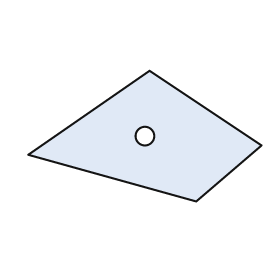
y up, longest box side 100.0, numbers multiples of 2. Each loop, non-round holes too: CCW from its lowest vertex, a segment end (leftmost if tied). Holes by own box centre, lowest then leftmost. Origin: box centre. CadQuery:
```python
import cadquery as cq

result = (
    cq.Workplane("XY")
    .moveTo(22.0, -28.0)
    .lineTo(50.0, -4.0)
    .lineTo(2.0, 28.0)
    .lineTo(-50.0, -8.0)
    .close()
    .moveTo(0.0, 0.0)
    .circle(4.0)
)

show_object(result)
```